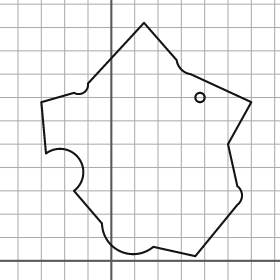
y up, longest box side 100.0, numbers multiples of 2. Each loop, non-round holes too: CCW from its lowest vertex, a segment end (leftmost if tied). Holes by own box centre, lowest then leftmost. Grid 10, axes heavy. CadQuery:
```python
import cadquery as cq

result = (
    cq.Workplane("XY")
    .moveTo(36.0, 2.0)
    .lineTo(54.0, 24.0)
    .threePointArc((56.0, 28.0), (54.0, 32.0))
    .lineTo(50.0, 50.0)
    .lineTo(60.0, 68.0)
    .lineTo(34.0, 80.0)
    .threePointArc((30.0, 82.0), (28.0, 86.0))
    .lineTo(14.0, 102.0)
    .lineTo(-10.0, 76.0)
    .threePointArc((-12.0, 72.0), (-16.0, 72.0))
    .lineTo(-30.0, 68.0)
    .lineTo(-28.0, 46.0)
    .threePointArc((-14.0, 44.0), (-16.0, 30.0))
    .lineTo(-4.0, 16.0)
    .threePointArc((4.0, 4.0), (18.0, 6.0))
    .close()
    .moveTo(38.0, 70.0)
    .circle(2.0)
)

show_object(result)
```